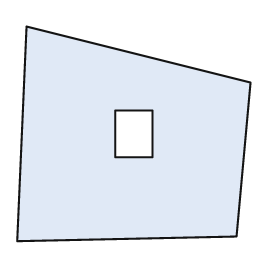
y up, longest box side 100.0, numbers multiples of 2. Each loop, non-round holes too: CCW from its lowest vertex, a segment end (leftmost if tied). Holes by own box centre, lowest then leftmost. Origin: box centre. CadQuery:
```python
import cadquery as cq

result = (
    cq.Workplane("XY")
    .moveTo(-50.0, -46.0)
    .lineTo(44.0, -44.0)
    .lineTo(50.0, 22.0)
    .lineTo(-46.0, 46.0)
    .close()
    .moveTo(-8.0, -10.0)
    .lineTo(8.0, -10.0)
    .lineTo(8.0, 10.0)
    .lineTo(-8.0, 10.0)
    .close()
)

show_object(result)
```